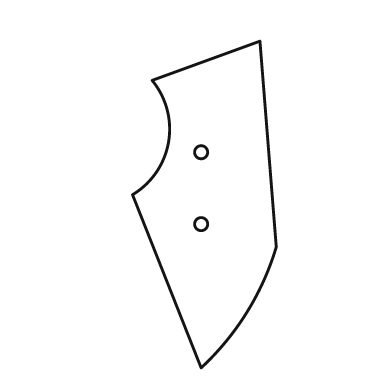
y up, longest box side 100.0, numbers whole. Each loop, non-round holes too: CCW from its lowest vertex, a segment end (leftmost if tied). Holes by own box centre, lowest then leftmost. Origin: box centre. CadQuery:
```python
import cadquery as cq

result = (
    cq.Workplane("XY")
    .moveTo(-1.0, -50.0)
    .threePointArc((13.0, -33.0), (22.0, -13.0))
    .lineTo(17.0, 50.0)
    .lineTo(-16.0, 38.0)
    .threePointArc((-11.0, 19.0), (-22.0, 3.0))
    .close()
    .moveTo(-1.0, -6.0)
    .circle(2.0)
    .moveTo(-1.0, 16.0)
    .circle(2.0)
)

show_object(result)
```